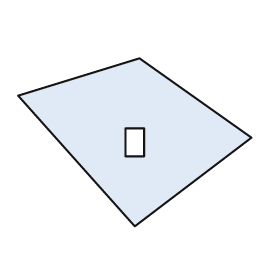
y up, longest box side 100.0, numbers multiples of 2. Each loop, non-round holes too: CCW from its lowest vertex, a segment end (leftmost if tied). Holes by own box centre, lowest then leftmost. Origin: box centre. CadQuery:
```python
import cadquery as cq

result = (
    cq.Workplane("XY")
    .moveTo(0.0, -36.0)
    .lineTo(50.0, 2.0)
    .lineTo(2.0, 36.0)
    .lineTo(-50.0, 20.0)
    .close()
    .moveTo(-4.0, -6.0)
    .lineTo(4.0, -6.0)
    .lineTo(4.0, 6.0)
    .lineTo(-4.0, 6.0)
    .close()
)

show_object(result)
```